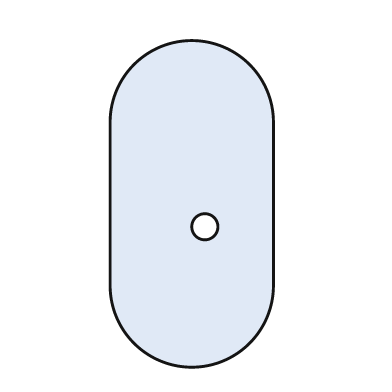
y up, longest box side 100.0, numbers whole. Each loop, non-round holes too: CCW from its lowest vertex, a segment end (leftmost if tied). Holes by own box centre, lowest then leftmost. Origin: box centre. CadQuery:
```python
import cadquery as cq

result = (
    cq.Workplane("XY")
    .moveTo(-25.0, -25.0)
    .threePointArc((0.0, -50.0), (25.0, -25.0))
    .lineTo(25.0, 25.0)
    .threePointArc((0.0, 50.0), (-25.0, 25.0))
    .close()
    .moveTo(4.0, -7.0)
    .circle(4.0)
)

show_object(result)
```